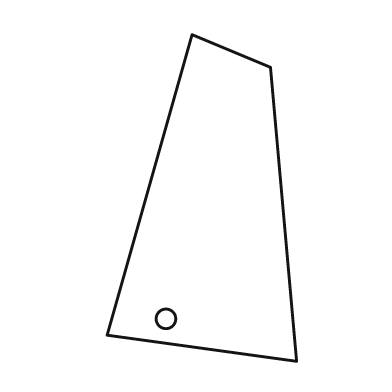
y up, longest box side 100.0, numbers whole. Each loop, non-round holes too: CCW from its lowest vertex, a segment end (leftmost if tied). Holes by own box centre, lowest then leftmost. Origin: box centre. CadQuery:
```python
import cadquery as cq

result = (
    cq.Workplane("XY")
    .moveTo(29.0, -50.0)
    .lineTo(21.0, 40.0)
    .lineTo(-3.0, 50.0)
    .lineTo(-29.0, -42.0)
    .close()
    .moveTo(-11.0, -37.0)
    .circle(3.0)
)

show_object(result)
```